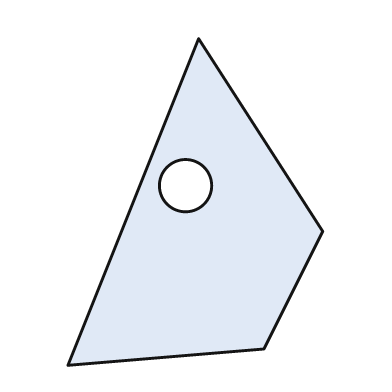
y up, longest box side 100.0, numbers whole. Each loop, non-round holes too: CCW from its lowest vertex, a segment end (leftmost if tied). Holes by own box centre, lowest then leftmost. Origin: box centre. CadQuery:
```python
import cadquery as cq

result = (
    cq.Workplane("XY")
    .moveTo(-39.0, -50.0)
    .lineTo(21.0, -45.0)
    .lineTo(39.0, -9.0)
    .lineTo(1.0, 50.0)
    .close()
    .moveTo(-3.0, 5.0)
    .circle(8.0)
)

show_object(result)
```